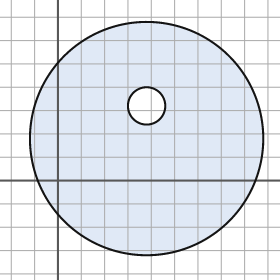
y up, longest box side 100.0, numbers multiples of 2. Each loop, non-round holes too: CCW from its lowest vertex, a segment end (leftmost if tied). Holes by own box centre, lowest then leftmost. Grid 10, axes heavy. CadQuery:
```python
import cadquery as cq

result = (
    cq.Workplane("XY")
    .moveTo(38.0, 18.0)
    .circle(50.0)
    .moveTo(38.0, 32.0)
    .circle(8.0)
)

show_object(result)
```